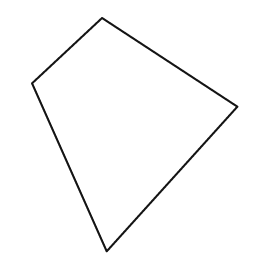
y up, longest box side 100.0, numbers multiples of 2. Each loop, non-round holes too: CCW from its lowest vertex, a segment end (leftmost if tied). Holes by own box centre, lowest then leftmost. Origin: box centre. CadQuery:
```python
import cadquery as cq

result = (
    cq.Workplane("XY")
    .moveTo(-12.0, -50.0)
    .lineTo(44.0, 12.0)
    .lineTo(-14.0, 50.0)
    .lineTo(-44.0, 22.0)
    .close()
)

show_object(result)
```